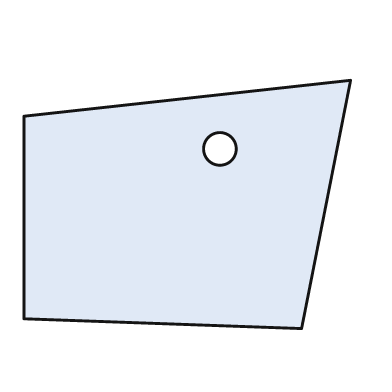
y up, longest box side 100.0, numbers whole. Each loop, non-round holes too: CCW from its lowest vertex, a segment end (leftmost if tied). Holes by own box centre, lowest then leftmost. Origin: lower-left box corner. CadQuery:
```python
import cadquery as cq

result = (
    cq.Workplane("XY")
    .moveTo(85.0, 0.0)
    .lineTo(100.0, 76.0)
    .lineTo(0.0, 65.0)
    .lineTo(0.0, 3.0)
    .close()
    .moveTo(60.0, 55.0)
    .circle(5.0)
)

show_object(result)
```